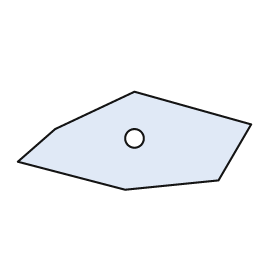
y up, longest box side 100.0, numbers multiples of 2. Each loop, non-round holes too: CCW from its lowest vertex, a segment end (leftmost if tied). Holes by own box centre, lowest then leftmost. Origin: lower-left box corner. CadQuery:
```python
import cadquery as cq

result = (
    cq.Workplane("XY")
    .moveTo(46.0, 0.0)
    .lineTo(86.0, 4.0)
    .lineTo(100.0, 28.0)
    .lineTo(50.0, 42.0)
    .lineTo(16.0, 26.0)
    .lineTo(0.0, 12.0)
    .close()
    .moveTo(50.0, 22.0)
    .circle(4.0)
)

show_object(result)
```